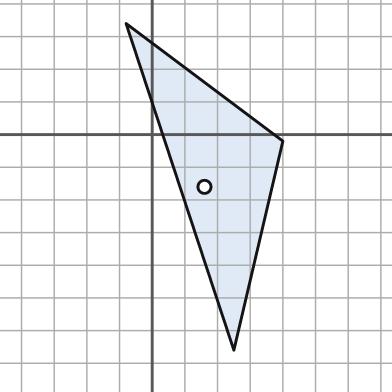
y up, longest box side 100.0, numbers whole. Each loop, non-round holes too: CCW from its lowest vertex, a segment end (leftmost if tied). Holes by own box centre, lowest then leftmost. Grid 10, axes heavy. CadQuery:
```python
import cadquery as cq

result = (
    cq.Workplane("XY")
    .moveTo(25.0, -66.0)
    .lineTo(40.0, -2.0)
    .lineTo(-8.0, 34.0)
    .close()
    .moveTo(16.0, -16.0)
    .circle(2.0)
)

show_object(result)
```